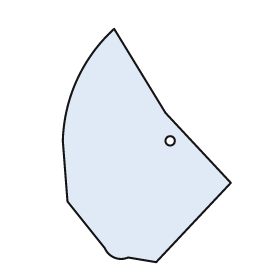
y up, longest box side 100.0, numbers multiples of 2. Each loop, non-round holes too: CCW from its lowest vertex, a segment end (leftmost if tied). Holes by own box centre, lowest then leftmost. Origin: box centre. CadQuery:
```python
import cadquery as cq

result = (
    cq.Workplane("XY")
    .moveTo(4.0, -50.0)
    .lineTo(36.0, -16.0)
    .lineTo(8.0, 14.0)
    .lineTo(-14.0, 50.0)
    .threePointArc((-30.0, 28.0), (-36.0, 2.0))
    .lineTo(-34.0, -24.0)
    .lineTo(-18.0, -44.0)
    .threePointArc((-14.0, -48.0), (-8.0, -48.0))
    .close()
    .moveTo(10.0, 2.0)
    .circle(2.0)
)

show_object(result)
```